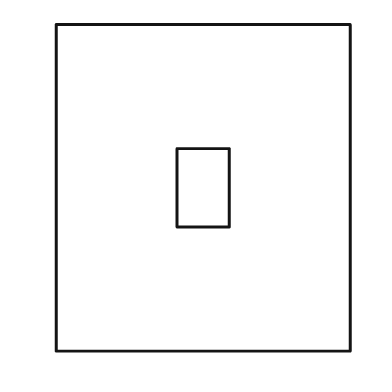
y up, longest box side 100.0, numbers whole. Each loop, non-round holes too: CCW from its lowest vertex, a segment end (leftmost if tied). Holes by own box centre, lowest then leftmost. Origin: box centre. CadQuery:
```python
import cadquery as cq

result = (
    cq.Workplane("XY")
    .moveTo(-45.0, -50.0)
    .lineTo(45.0, -50.0)
    .lineTo(45.0, 50.0)
    .lineTo(-45.0, 50.0)
    .close()
    .moveTo(-8.0, -12.0)
    .lineTo(8.0, -12.0)
    .lineTo(8.0, 12.0)
    .lineTo(-8.0, 12.0)
    .close()
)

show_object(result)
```